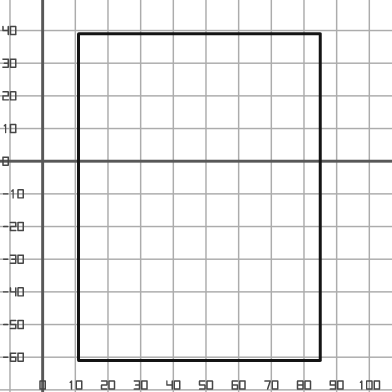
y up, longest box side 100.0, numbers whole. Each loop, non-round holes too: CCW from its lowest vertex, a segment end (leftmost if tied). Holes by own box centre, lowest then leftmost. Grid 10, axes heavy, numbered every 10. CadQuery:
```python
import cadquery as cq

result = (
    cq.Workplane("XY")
    .moveTo(11.0, -61.0)
    .lineTo(85.0, -61.0)
    .lineTo(85.0, 39.0)
    .lineTo(11.0, 39.0)
    .close()
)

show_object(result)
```